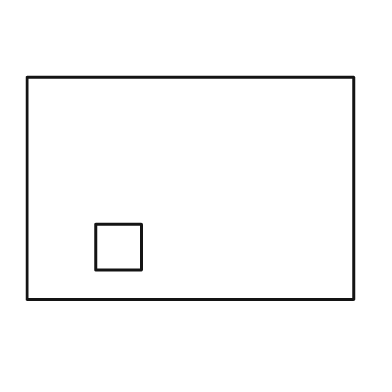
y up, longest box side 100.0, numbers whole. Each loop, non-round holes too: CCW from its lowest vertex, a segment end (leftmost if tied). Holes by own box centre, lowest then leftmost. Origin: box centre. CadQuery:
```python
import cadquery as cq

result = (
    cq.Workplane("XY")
    .moveTo(-50.0, -34.0)
    .lineTo(50.0, -34.0)
    .lineTo(50.0, 34.0)
    .lineTo(-50.0, 34.0)
    .close()
    .moveTo(-29.0, -25.0)
    .lineTo(-15.0, -25.0)
    .lineTo(-15.0, -11.0)
    .lineTo(-29.0, -11.0)
    .close()
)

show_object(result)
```